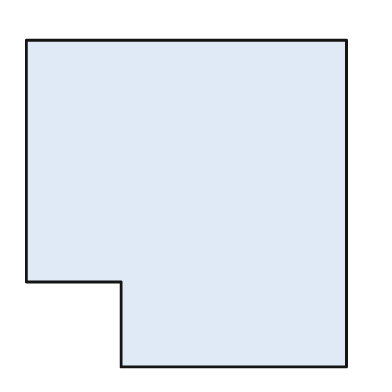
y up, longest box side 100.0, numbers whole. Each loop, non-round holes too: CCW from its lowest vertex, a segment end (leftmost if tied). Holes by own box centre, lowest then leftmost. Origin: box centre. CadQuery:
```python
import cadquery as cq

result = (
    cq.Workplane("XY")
    .moveTo(-20.0, -50.0)
    .lineTo(49.0, -50.0)
    .lineTo(49.0, 50.0)
    .lineTo(-49.0, 50.0)
    .lineTo(-49.0, -24.0)
    .lineTo(-20.0, -24.0)
    .close()
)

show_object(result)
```